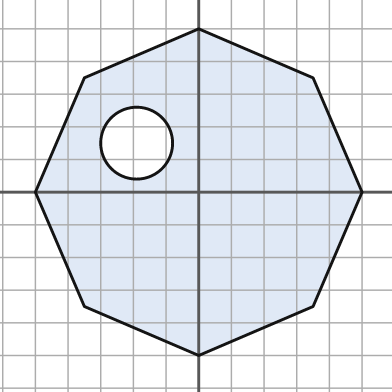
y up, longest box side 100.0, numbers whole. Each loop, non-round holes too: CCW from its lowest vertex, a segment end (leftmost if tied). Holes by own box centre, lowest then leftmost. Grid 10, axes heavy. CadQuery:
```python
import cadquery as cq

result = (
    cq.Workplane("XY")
    .moveTo(0.0, -50.0)
    .lineTo(35.0, -35.0)
    .lineTo(50.0, 0.0)
    .lineTo(35.0, 35.0)
    .lineTo(0.0, 50.0)
    .lineTo(-35.0, 35.0)
    .lineTo(-50.0, 0.0)
    .lineTo(-35.0, -35.0)
    .close()
    .moveTo(-19.0, 15.0)
    .circle(11.0)
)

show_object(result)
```